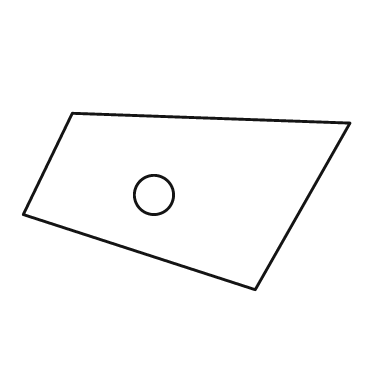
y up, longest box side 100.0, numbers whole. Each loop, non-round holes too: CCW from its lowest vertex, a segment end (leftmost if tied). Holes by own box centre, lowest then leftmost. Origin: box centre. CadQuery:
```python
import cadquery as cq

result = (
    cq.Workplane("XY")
    .moveTo(21.0, -27.0)
    .lineTo(50.0, 24.0)
    .lineTo(-35.0, 27.0)
    .lineTo(-50.0, -4.0)
    .close()
    .moveTo(-10.0, 2.0)
    .circle(6.0)
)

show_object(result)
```